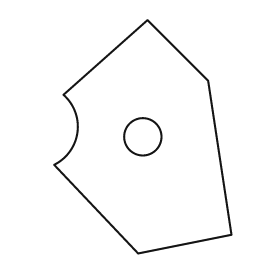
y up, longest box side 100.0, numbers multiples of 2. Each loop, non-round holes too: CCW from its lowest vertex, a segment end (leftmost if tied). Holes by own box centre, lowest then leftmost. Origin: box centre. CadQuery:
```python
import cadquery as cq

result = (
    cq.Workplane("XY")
    .moveTo(-2.0, -50.0)
    .lineTo(38.0, -42.0)
    .lineTo(28.0, 24.0)
    .lineTo(2.0, 50.0)
    .lineTo(-34.0, 18.0)
    .threePointArc((-28.0, 2.0), (-38.0, -12.0))
    .close()
    .moveTo(0.0, 0.0)
    .circle(8.0)
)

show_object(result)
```